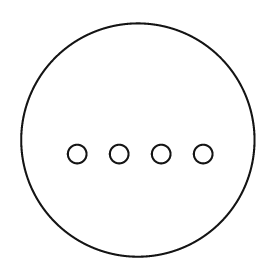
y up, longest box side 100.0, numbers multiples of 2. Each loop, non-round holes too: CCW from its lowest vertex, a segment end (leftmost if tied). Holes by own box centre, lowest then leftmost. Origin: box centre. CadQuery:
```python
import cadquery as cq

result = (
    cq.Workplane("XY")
    .moveTo(0.0, 0.0)
    .circle(50.0)
    .moveTo(-26.0, -6.0)
    .circle(4.0)
    .moveTo(-8.0, -6.0)
    .circle(4.0)
    .moveTo(10.0, -6.0)
    .circle(4.0)
    .moveTo(28.0, -6.0)
    .circle(4.0)
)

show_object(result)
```